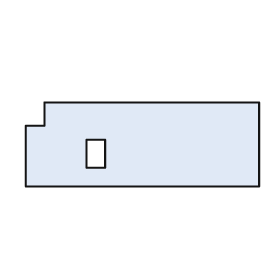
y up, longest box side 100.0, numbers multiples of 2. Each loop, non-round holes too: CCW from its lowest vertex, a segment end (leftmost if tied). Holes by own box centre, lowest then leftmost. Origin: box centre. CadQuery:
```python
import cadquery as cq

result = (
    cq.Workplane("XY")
    .moveTo(-50.0, -18.0)
    .lineTo(50.0, -18.0)
    .lineTo(50.0, 18.0)
    .lineTo(-42.0, 18.0)
    .lineTo(-42.0, 8.0)
    .lineTo(-50.0, 8.0)
    .close()
    .moveTo(-24.0, -10.0)
    .lineTo(-16.0, -10.0)
    .lineTo(-16.0, 2.0)
    .lineTo(-24.0, 2.0)
    .close()
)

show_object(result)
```